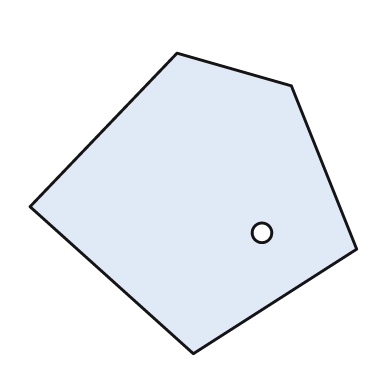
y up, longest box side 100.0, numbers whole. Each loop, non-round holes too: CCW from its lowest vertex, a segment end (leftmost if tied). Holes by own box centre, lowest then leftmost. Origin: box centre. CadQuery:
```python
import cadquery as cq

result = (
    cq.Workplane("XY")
    .moveTo(0.0, -46.0)
    .lineTo(50.0, -14.0)
    .lineTo(30.0, 36.0)
    .lineTo(-5.0, 46.0)
    .lineTo(-50.0, -1.0)
    .close()
    .moveTo(21.0, -9.0)
    .circle(3.0)
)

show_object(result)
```